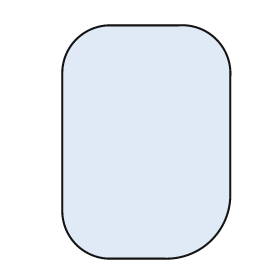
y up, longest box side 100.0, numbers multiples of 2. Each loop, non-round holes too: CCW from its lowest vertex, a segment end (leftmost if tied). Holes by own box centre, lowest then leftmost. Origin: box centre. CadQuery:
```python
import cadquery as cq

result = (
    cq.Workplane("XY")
    .moveTo(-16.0, -50.0)
    .lineTo(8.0, -50.0)
    .threePointArc((28.0, -42.0), (36.0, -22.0))
    .lineTo(36.0, 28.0)
    .threePointArc((30.0, 44.0), (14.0, 50.0))
    .lineTo(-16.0, 50.0)
    .threePointArc((-30.0, 44.0), (-36.0, 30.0))
    .lineTo(-36.0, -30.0)
    .threePointArc((-30.0, -44.0), (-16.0, -50.0))
    .close()
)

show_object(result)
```